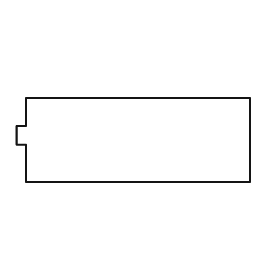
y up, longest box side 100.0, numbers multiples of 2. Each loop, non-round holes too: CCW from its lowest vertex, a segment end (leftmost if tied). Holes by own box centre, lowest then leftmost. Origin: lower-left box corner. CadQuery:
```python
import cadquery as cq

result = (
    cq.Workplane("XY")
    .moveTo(4.0, 0.0)
    .lineTo(100.0, 0.0)
    .lineTo(100.0, 36.0)
    .lineTo(4.0, 36.0)
    .lineTo(4.0, 24.0)
    .lineTo(0.0, 24.0)
    .lineTo(0.0, 16.0)
    .lineTo(4.0, 16.0)
    .close()
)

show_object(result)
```